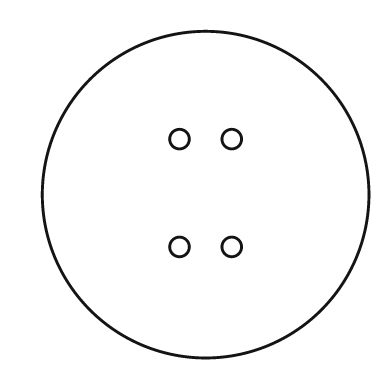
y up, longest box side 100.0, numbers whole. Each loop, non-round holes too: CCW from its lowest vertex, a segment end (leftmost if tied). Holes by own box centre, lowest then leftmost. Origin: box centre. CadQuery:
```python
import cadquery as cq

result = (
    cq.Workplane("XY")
    .moveTo(0.0, 0.0)
    .circle(50.0)
    .moveTo(-8.0, -16.0)
    .circle(3.0)
    .moveTo(8.0, -16.0)
    .circle(3.0)
    .moveTo(-8.0, 17.0)
    .circle(3.0)
    .moveTo(8.0, 17.0)
    .circle(3.0)
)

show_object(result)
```